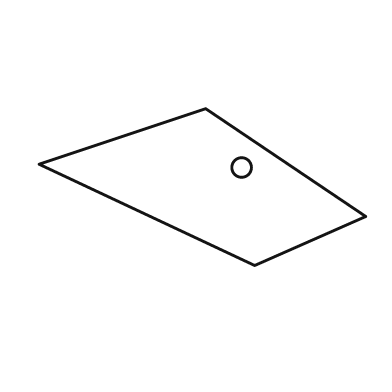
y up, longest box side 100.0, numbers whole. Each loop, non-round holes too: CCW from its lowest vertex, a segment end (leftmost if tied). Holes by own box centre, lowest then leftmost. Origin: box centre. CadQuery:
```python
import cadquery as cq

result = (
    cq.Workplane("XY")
    .moveTo(16.0, -24.0)
    .lineTo(50.0, -9.0)
    .lineTo(1.0, 24.0)
    .lineTo(-50.0, 7.0)
    .close()
    .moveTo(12.0, 6.0)
    .circle(3.0)
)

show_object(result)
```